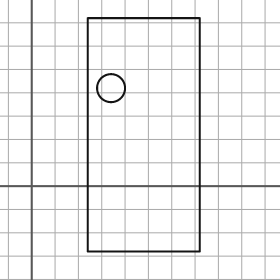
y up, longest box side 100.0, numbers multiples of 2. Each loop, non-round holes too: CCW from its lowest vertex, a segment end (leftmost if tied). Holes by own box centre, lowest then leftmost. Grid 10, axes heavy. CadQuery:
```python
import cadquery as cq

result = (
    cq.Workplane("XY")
    .moveTo(24.0, -28.0)
    .lineTo(72.0, -28.0)
    .lineTo(72.0, 72.0)
    .lineTo(24.0, 72.0)
    .close()
    .moveTo(34.0, 42.0)
    .circle(6.0)
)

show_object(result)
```